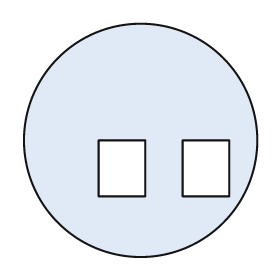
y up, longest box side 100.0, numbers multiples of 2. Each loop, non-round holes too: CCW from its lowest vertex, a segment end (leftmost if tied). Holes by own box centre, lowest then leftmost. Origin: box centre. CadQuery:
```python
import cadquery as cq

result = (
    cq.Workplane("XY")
    .moveTo(0.0, 0.0)
    .circle(50.0)
    .moveTo(-18.0, -24.0)
    .lineTo(2.0, -24.0)
    .lineTo(2.0, 0.0)
    .lineTo(-18.0, 0.0)
    .close()
    .moveTo(18.0, -24.0)
    .lineTo(38.0, -24.0)
    .lineTo(38.0, 0.0)
    .lineTo(18.0, 0.0)
    .close()
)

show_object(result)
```